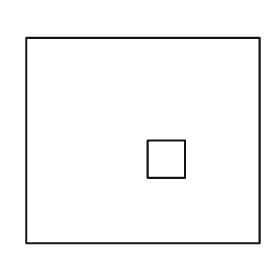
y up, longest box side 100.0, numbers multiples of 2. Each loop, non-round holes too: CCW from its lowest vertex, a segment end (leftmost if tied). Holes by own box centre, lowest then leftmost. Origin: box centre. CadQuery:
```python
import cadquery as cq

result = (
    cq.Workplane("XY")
    .moveTo(-50.0, -44.0)
    .lineTo(50.0, -44.0)
    .lineTo(50.0, 44.0)
    .lineTo(-50.0, 44.0)
    .close()
    .moveTo(2.0, -16.0)
    .lineTo(18.0, -16.0)
    .lineTo(18.0, 0.0)
    .lineTo(2.0, 0.0)
    .close()
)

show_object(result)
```